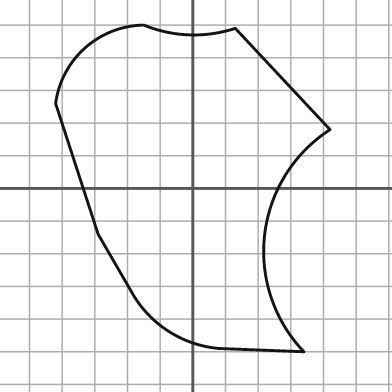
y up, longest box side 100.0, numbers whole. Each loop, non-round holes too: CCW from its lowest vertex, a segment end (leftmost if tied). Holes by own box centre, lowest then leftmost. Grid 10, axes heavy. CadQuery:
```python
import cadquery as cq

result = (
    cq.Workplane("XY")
    .moveTo(34.0, -50.0)
    .threePointArc((22.0, -14.0), (42.0, 18.0))
    .lineTo(13.0, 49.0)
    .threePointArc((-1.0, 47.0), (-15.0, 50.0))
    .threePointArc((-33.0, 43.0), (-42.0, 26.0))
    .lineTo(-29.0, -14.0)
    .lineTo(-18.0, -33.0)
    .threePointArc((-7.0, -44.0), (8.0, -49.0))
    .close()
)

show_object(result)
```